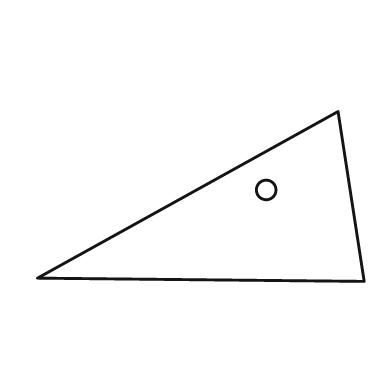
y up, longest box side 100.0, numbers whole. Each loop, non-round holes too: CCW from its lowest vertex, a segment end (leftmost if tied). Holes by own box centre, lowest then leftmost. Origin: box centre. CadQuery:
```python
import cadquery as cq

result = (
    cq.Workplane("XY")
    .moveTo(50.0, -26.0)
    .lineTo(42.0, 26.0)
    .lineTo(-50.0, -25.0)
    .close()
    .moveTo(20.0, 2.0)
    .circle(3.0)
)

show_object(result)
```